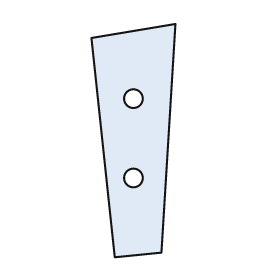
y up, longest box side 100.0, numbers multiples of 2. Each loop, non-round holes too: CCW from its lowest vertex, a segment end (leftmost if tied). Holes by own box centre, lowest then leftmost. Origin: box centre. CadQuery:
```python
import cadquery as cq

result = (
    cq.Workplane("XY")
    .moveTo(-8.0, -50.0)
    .lineTo(12.0, -48.0)
    .lineTo(18.0, 50.0)
    .lineTo(-18.0, 44.0)
    .close()
    .moveTo(0.0, -16.0)
    .circle(4.0)
    .moveTo(0.0, 18.0)
    .circle(4.0)
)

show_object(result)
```